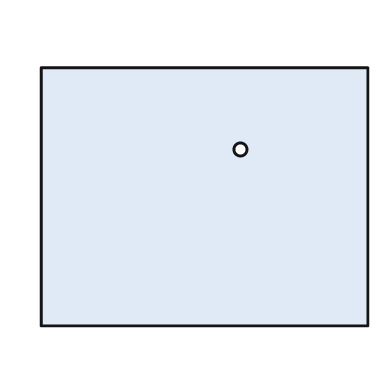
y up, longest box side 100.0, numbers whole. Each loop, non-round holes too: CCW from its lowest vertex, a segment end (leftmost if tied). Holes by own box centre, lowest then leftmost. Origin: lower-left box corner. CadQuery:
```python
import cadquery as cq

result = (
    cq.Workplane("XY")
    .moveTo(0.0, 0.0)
    .lineTo(100.0, 0.0)
    .lineTo(100.0, 79.0)
    .lineTo(0.0, 79.0)
    .close()
    .moveTo(61.0, 54.0)
    .circle(2.0)
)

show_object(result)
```